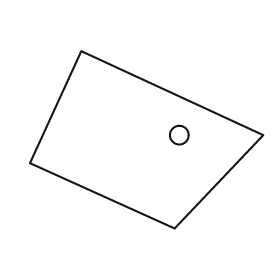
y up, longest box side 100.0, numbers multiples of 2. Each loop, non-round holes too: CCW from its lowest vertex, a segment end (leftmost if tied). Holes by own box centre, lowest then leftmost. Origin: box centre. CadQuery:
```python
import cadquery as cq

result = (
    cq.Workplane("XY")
    .moveTo(12.0, -38.0)
    .lineTo(50.0, 2.0)
    .lineTo(-28.0, 38.0)
    .lineTo(-50.0, -10.0)
    .close()
    .moveTo(14.0, 2.0)
    .circle(4.0)
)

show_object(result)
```